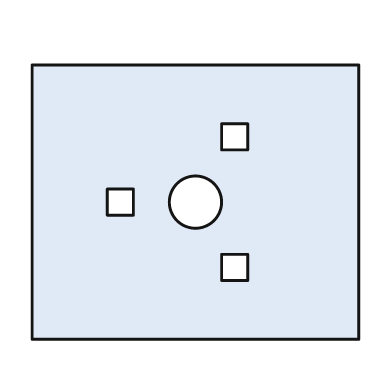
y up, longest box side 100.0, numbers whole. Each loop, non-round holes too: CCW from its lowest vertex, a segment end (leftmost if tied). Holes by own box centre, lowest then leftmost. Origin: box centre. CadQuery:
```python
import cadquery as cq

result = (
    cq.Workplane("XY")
    .moveTo(-50.0, -42.0)
    .lineTo(50.0, -42.0)
    .lineTo(50.0, 42.0)
    .lineTo(-50.0, 42.0)
    .close()
    .moveTo(8.0, -24.0)
    .lineTo(16.0, -24.0)
    .lineTo(16.0, -16.0)
    .lineTo(8.0, -16.0)
    .close()
    .moveTo(-27.0, -4.0)
    .lineTo(-19.0, -4.0)
    .lineTo(-19.0, 4.0)
    .lineTo(-27.0, 4.0)
    .close()
    .moveTo(0.0, 0.0)
    .circle(8.0)
    .moveTo(8.0, 16.0)
    .lineTo(16.0, 16.0)
    .lineTo(16.0, 24.0)
    .lineTo(8.0, 24.0)
    .close()
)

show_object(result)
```